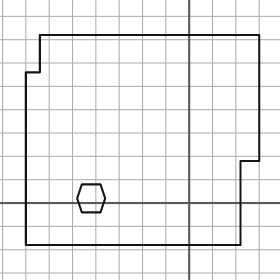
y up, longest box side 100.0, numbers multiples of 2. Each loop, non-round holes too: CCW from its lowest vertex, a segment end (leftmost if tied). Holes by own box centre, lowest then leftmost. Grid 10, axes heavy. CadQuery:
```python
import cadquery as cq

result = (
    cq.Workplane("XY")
    .moveTo(-70.0, -18.0)
    .lineTo(22.0, -18.0)
    .lineTo(22.0, 18.0)
    .lineTo(30.0, 18.0)
    .lineTo(30.0, 72.0)
    .lineTo(-64.0, 72.0)
    .lineTo(-64.0, 56.0)
    .lineTo(-70.0, 56.0)
    .close()
    .moveTo(-46.0, -4.0)
    .lineTo(-38.0, -4.0)
    .lineTo(-36.0, 2.0)
    .lineTo(-38.0, 8.0)
    .lineTo(-46.0, 8.0)
    .lineTo(-48.0, 2.0)
    .close()
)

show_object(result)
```